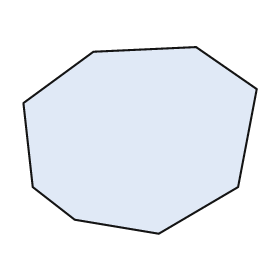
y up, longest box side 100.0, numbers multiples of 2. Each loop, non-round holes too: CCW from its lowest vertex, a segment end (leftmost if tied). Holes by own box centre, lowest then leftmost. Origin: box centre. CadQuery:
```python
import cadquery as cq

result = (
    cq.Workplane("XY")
    .moveTo(8.0, -40.0)
    .lineTo(42.0, -20.0)
    .lineTo(50.0, 22.0)
    .lineTo(24.0, 40.0)
    .lineTo(-20.0, 38.0)
    .lineTo(-50.0, 16.0)
    .lineTo(-46.0, -20.0)
    .lineTo(-28.0, -34.0)
    .close()
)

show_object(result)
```